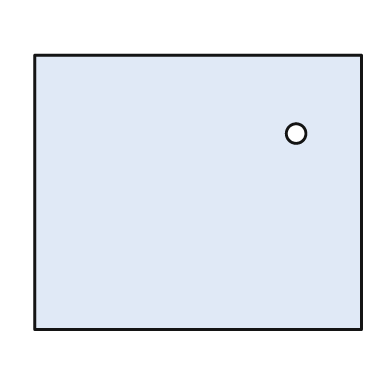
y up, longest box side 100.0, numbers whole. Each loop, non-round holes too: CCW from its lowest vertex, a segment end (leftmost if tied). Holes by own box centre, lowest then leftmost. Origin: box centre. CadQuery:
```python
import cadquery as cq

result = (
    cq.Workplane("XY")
    .moveTo(-50.0, -42.0)
    .lineTo(50.0, -42.0)
    .lineTo(50.0, 42.0)
    .lineTo(-50.0, 42.0)
    .close()
    .moveTo(30.0, 18.0)
    .circle(3.0)
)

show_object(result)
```